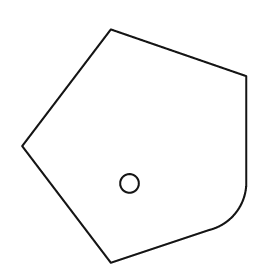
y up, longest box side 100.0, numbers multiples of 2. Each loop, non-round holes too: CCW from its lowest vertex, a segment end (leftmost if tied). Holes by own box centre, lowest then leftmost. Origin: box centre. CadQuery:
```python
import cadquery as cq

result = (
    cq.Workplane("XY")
    .moveTo(-10.0, -50.0)
    .lineTo(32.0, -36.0)
    .threePointArc((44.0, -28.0), (48.0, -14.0))
    .lineTo(48.0, 30.0)
    .lineTo(-10.0, 50.0)
    .lineTo(-48.0, 0.0)
    .close()
    .moveTo(-2.0, -16.0)
    .circle(4.0)
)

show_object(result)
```